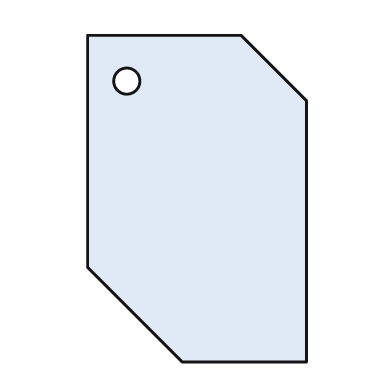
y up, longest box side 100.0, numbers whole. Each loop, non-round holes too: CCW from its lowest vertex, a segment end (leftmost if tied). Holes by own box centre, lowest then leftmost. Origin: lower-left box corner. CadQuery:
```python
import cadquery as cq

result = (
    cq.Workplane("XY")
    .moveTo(29.0, 0.0)
    .lineTo(67.0, 0.0)
    .lineTo(67.0, 80.0)
    .lineTo(47.0, 100.0)
    .lineTo(0.0, 100.0)
    .lineTo(0.0, 29.0)
    .close()
    .moveTo(12.0, 86.0)
    .circle(4.0)
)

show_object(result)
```